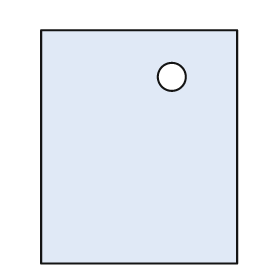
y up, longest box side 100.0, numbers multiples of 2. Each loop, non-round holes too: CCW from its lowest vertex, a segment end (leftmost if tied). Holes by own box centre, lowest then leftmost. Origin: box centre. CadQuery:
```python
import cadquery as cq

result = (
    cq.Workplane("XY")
    .moveTo(-42.0, -50.0)
    .lineTo(42.0, -50.0)
    .lineTo(42.0, 50.0)
    .lineTo(-42.0, 50.0)
    .close()
    .moveTo(14.0, 30.0)
    .circle(6.0)
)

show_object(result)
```